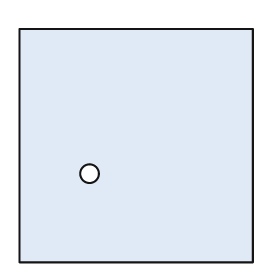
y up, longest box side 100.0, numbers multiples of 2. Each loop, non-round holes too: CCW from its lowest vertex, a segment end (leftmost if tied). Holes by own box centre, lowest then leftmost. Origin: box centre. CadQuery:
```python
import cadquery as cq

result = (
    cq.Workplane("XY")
    .moveTo(-50.0, -50.0)
    .lineTo(50.0, -50.0)
    .lineTo(50.0, 50.0)
    .lineTo(-50.0, 50.0)
    .close()
    .moveTo(-20.0, -12.0)
    .circle(4.0)
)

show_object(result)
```